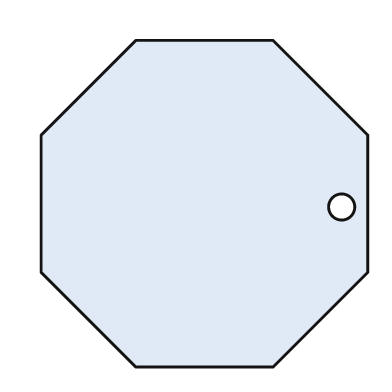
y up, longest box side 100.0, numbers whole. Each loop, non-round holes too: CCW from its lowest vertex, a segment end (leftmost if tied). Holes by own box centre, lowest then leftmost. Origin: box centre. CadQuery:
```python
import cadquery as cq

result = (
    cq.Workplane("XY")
    .moveTo(-21.0, -50.0)
    .lineTo(21.0, -50.0)
    .lineTo(50.0, -21.0)
    .lineTo(50.0, 21.0)
    .lineTo(21.0, 50.0)
    .lineTo(-21.0, 50.0)
    .lineTo(-50.0, 21.0)
    .lineTo(-50.0, -21.0)
    .close()
    .moveTo(42.0, -1.0)
    .circle(4.0)
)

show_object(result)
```